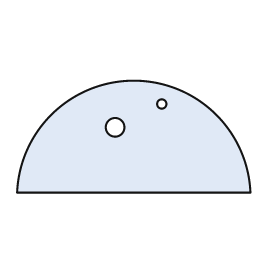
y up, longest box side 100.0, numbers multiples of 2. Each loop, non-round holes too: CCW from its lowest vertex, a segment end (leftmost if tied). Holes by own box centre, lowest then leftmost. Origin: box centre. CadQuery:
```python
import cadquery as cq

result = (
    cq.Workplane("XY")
    .moveTo(-50.0, -24.0)
    .lineTo(50.0, -24.0)
    .threePointArc((0.0, 24.0), (-50.0, -24.0))
    .close()
    .moveTo(-8.0, 4.0)
    .circle(4.0)
    .moveTo(12.0, 14.0)
    .circle(2.0)
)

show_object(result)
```